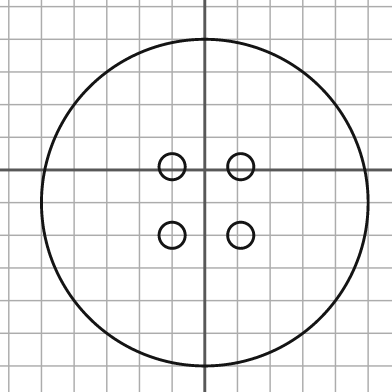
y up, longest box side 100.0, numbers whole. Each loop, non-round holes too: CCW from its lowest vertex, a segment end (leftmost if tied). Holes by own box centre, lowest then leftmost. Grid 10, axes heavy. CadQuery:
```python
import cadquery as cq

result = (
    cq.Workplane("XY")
    .moveTo(0.0, -10.0)
    .circle(50.0)
    .moveTo(-10.0, -20.0)
    .circle(4.0)
    .moveTo(11.0, -20.0)
    .circle(4.0)
    .moveTo(-10.0, 1.0)
    .circle(4.0)
    .moveTo(11.0, 1.0)
    .circle(4.0)
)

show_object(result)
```